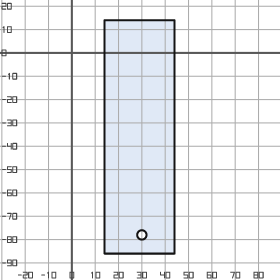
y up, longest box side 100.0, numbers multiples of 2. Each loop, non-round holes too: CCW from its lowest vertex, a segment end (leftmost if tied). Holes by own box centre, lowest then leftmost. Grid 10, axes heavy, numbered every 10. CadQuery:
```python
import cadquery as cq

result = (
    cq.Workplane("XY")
    .moveTo(14.0, -86.0)
    .lineTo(44.0, -86.0)
    .lineTo(44.0, 14.0)
    .lineTo(14.0, 14.0)
    .close()
    .moveTo(30.0, -78.0)
    .circle(2.0)
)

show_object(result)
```